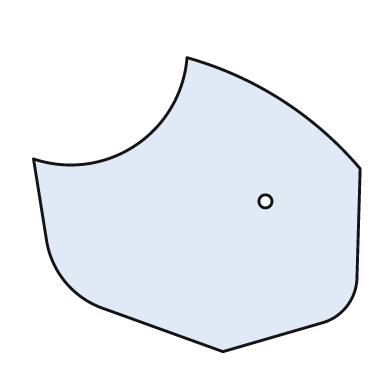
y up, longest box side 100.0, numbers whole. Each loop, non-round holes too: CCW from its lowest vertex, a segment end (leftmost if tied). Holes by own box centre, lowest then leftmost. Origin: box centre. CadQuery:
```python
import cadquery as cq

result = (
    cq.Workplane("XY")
    .moveTo(8.0, -45.0)
    .lineTo(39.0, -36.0)
    .threePointArc((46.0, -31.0), (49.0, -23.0))
    .lineTo(50.0, 11.0)
    .threePointArc((26.0, 32.0), (-3.0, 45.0))
    .threePointArc((-19.0, 18.0), (-50.0, 14.0))
    .lineTo(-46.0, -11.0)
    .threePointArc((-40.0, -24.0), (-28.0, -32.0))
    .close()
    .moveTo(21.0, 1.0)
    .circle(2.0)
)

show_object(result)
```